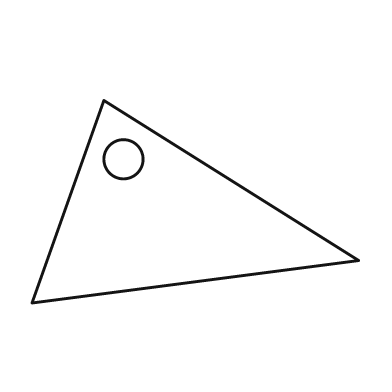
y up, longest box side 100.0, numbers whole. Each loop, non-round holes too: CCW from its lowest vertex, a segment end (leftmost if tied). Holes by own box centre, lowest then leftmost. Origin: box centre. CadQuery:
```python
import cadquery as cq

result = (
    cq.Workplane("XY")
    .moveTo(-50.0, -31.0)
    .lineTo(50.0, -18.0)
    .lineTo(-28.0, 31.0)
    .close()
    .moveTo(-22.0, 13.0)
    .circle(6.0)
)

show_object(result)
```